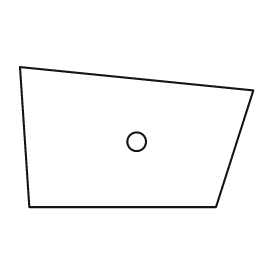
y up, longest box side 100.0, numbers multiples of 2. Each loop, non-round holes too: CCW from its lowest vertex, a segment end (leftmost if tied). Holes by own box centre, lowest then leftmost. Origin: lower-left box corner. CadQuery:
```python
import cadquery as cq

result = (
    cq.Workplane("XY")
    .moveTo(4.0, 0.0)
    .lineTo(84.0, 0.0)
    .lineTo(100.0, 50.0)
    .lineTo(0.0, 60.0)
    .close()
    .moveTo(50.0, 28.0)
    .circle(4.0)
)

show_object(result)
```